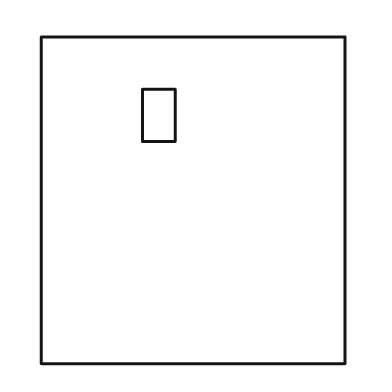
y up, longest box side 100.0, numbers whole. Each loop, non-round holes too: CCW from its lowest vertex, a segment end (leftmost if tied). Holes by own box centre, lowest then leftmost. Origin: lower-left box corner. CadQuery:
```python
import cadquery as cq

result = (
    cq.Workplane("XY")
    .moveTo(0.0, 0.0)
    .lineTo(93.0, 0.0)
    .lineTo(93.0, 100.0)
    .lineTo(0.0, 100.0)
    .close()
    .moveTo(31.0, 68.0)
    .lineTo(41.0, 68.0)
    .lineTo(41.0, 84.0)
    .lineTo(31.0, 84.0)
    .close()
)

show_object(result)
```